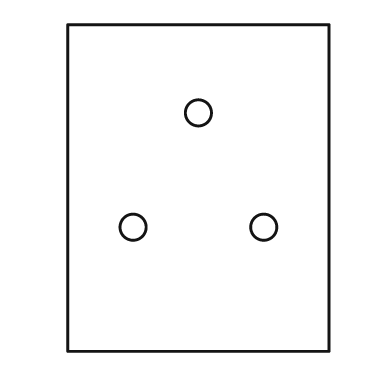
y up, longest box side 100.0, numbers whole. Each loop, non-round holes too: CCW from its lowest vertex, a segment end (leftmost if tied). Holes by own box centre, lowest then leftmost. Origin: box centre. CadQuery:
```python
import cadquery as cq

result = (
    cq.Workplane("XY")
    .moveTo(-40.0, -50.0)
    .lineTo(40.0, -50.0)
    .lineTo(40.0, 50.0)
    .lineTo(-40.0, 50.0)
    .close()
    .moveTo(-20.0, -12.0)
    .circle(4.0)
    .moveTo(20.0, -12.0)
    .circle(4.0)
    .moveTo(0.0, 23.0)
    .circle(4.0)
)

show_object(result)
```